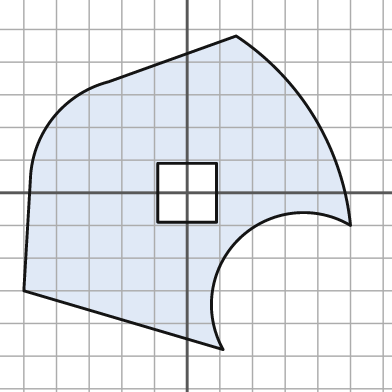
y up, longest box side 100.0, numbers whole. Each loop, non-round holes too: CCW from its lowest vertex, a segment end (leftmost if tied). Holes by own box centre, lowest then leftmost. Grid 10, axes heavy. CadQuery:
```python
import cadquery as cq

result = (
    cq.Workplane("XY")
    .moveTo(11.0, -48.0)
    .threePointArc((16.0, -14.0), (50.0, -10.0))
    .threePointArc((39.0, 23.0), (15.0, 48.0))
    .lineTo(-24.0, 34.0)
    .threePointArc((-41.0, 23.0), (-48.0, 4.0))
    .lineTo(-50.0, -30.0)
    .close()
    .moveTo(-9.0, -9.0)
    .lineTo(9.0, -9.0)
    .lineTo(9.0, 9.0)
    .lineTo(-9.0, 9.0)
    .close()
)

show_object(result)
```